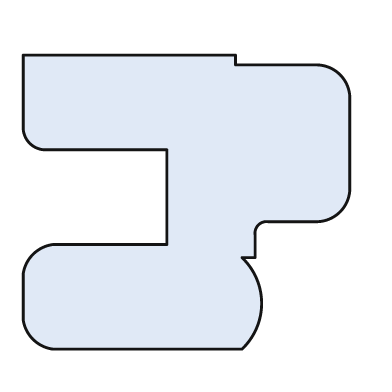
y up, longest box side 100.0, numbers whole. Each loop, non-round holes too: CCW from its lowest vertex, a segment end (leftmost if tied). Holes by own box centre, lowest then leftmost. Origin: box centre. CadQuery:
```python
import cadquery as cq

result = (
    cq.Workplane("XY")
    .moveTo(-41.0, -45.0)
    .lineTo(17.0, -45.0)
    .threePointArc((23.0, -31.0), (17.0, -17.0))
    .lineTo(21.0, -17.0)
    .lineTo(21.0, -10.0)
    .threePointArc((22.0, -7.0), (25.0, -6.0))
    .lineTo(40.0, -6.0)
    .threePointArc((47.0, -3.0), (50.0, 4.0))
    .lineTo(50.0, 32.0)
    .threePointArc((47.0, 39.0), (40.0, 42.0))
    .lineTo(15.0, 42.0)
    .lineTo(15.0, 45.0)
    .lineTo(-50.0, 45.0)
    .lineTo(-50.0, 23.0)
    .threePointArc((-48.0, 18.0), (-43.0, 16.0))
    .lineTo(-6.0, 16.0)
    .lineTo(-6.0, -13.0)
    .lineTo(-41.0, -13.0)
    .threePointArc((-47.0, -16.0), (-50.0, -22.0))
    .lineTo(-50.0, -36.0)
    .threePointArc((-47.0, -42.0), (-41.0, -45.0))
    .close()
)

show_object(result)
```